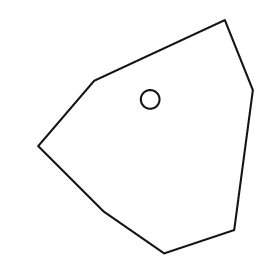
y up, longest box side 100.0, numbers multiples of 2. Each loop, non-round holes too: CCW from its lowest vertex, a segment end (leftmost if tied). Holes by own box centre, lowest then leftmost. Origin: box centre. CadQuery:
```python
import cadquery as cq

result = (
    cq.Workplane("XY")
    .moveTo(8.0, -50.0)
    .lineTo(38.0, -40.0)
    .lineTo(46.0, 20.0)
    .lineTo(34.0, 50.0)
    .lineTo(-22.0, 24.0)
    .lineTo(-46.0, -4.0)
    .lineTo(-18.0, -32.0)
    .close()
    .moveTo(2.0, 16.0)
    .circle(4.0)
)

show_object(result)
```